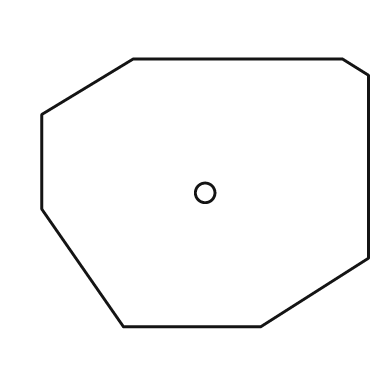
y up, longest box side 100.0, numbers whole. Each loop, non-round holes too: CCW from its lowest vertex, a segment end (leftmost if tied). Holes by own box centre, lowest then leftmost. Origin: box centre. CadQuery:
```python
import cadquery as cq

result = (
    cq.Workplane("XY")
    .moveTo(-25.0, -41.0)
    .lineTo(17.0, -41.0)
    .lineTo(50.0, -20.0)
    .lineTo(50.0, 36.0)
    .lineTo(42.0, 41.0)
    .lineTo(-22.0, 41.0)
    .lineTo(-50.0, 24.0)
    .lineTo(-50.0, -5.0)
    .close()
    .moveTo(0.0, 0.0)
    .circle(3.0)
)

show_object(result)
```